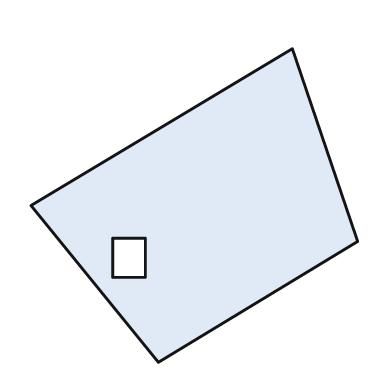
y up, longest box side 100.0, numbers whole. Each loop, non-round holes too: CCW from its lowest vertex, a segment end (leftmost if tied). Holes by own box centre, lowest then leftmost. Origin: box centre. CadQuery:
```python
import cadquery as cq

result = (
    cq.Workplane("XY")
    .moveTo(-11.0, -48.0)
    .lineTo(50.0, -11.0)
    .lineTo(30.0, 48.0)
    .lineTo(-50.0, 0.0)
    .close()
    .moveTo(-25.0, -22.0)
    .lineTo(-15.0, -22.0)
    .lineTo(-15.0, -10.0)
    .lineTo(-25.0, -10.0)
    .close()
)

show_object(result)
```